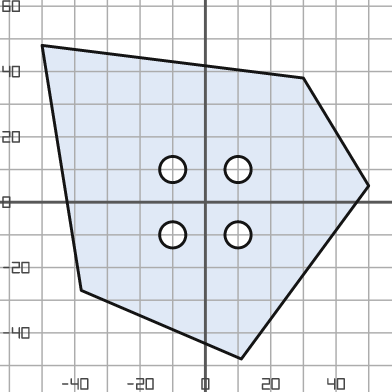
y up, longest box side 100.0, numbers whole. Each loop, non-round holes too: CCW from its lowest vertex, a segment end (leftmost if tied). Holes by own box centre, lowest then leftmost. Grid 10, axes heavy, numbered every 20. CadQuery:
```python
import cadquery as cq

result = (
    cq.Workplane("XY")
    .moveTo(11.0, -48.0)
    .lineTo(50.0, 5.0)
    .lineTo(30.0, 38.0)
    .lineTo(-50.0, 48.0)
    .lineTo(-38.0, -27.0)
    .close()
    .moveTo(-10.0, -10.0)
    .circle(4.0)
    .moveTo(10.0, -10.0)
    .circle(4.0)
    .moveTo(-10.0, 10.0)
    .circle(4.0)
    .moveTo(10.0, 10.0)
    .circle(4.0)
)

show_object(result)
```